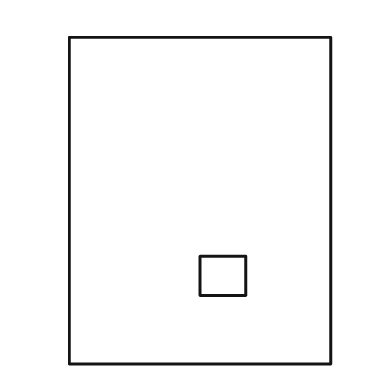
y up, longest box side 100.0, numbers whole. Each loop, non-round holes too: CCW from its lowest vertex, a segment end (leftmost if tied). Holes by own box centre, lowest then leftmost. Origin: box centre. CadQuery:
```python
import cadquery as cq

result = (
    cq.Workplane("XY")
    .moveTo(-40.0, -50.0)
    .lineTo(40.0, -50.0)
    .lineTo(40.0, 50.0)
    .lineTo(-40.0, 50.0)
    .close()
    .moveTo(0.0, -29.0)
    .lineTo(14.0, -29.0)
    .lineTo(14.0, -17.0)
    .lineTo(0.0, -17.0)
    .close()
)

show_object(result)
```